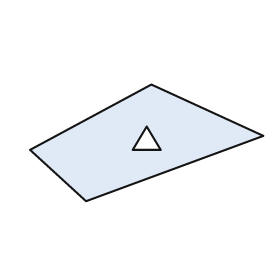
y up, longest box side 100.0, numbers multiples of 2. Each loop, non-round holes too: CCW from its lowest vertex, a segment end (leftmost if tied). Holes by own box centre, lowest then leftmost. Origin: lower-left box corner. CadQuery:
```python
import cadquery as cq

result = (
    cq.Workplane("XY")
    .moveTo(24.0, 0.0)
    .lineTo(100.0, 28.0)
    .lineTo(52.0, 50.0)
    .lineTo(0.0, 22.0)
    .close()
    .moveTo(44.0, 22.0)
    .lineTo(56.0, 22.0)
    .lineTo(50.0, 32.0)
    .close()
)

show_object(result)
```